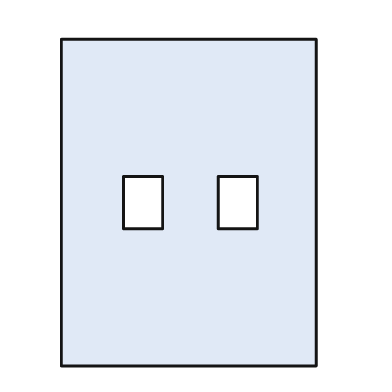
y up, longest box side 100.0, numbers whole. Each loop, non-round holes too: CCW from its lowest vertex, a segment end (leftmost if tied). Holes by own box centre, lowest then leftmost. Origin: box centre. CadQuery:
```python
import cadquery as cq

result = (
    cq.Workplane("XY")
    .moveTo(-39.0, -50.0)
    .lineTo(39.0, -50.0)
    .lineTo(39.0, 50.0)
    .lineTo(-39.0, 50.0)
    .close()
    .moveTo(-20.0, -8.0)
    .lineTo(-8.0, -8.0)
    .lineTo(-8.0, 8.0)
    .lineTo(-20.0, 8.0)
    .close()
    .moveTo(9.0, -8.0)
    .lineTo(21.0, -8.0)
    .lineTo(21.0, 8.0)
    .lineTo(9.0, 8.0)
    .close()
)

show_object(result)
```